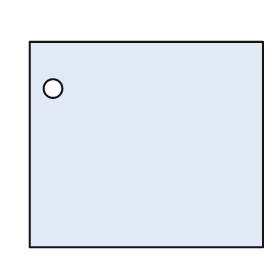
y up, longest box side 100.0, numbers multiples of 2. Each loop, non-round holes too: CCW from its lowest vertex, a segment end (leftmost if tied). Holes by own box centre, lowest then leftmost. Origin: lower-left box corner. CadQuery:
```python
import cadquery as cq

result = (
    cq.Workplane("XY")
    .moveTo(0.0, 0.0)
    .lineTo(100.0, 0.0)
    .lineTo(100.0, 88.0)
    .lineTo(0.0, 88.0)
    .close()
    .moveTo(10.0, 68.0)
    .circle(4.0)
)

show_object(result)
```